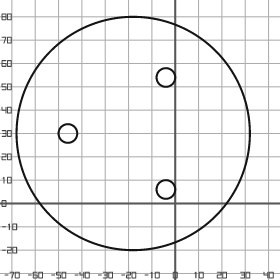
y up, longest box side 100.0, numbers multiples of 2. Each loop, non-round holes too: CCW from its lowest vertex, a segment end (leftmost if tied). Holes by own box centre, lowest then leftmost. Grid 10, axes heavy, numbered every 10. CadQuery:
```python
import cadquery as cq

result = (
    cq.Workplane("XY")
    .moveTo(-18.0, 30.0)
    .circle(50.0)
    .moveTo(-4.0, 6.0)
    .circle(4.0)
    .moveTo(-46.0, 30.0)
    .circle(4.0)
    .moveTo(-4.0, 54.0)
    .circle(4.0)
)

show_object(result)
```